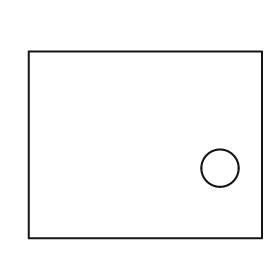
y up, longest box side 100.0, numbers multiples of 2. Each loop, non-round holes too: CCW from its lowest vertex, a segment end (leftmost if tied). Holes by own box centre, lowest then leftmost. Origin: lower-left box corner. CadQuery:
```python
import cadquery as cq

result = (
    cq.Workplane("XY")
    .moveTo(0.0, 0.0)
    .lineTo(100.0, 0.0)
    .lineTo(100.0, 80.0)
    .lineTo(0.0, 80.0)
    .close()
    .moveTo(82.0, 30.0)
    .circle(8.0)
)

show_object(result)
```